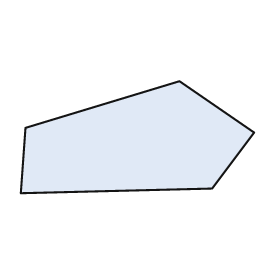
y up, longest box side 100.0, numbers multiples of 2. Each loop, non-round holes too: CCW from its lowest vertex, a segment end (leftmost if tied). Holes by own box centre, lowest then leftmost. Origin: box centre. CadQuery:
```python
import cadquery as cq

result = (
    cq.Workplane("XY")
    .moveTo(-50.0, -24.0)
    .lineTo(32.0, -22.0)
    .lineTo(50.0, 2.0)
    .lineTo(18.0, 24.0)
    .lineTo(-48.0, 4.0)
    .close()
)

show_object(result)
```